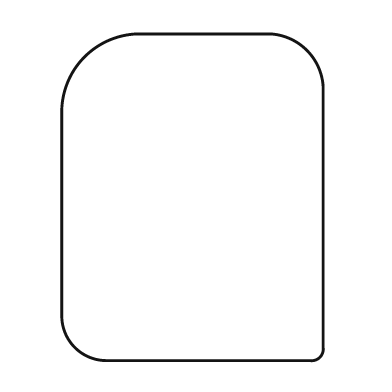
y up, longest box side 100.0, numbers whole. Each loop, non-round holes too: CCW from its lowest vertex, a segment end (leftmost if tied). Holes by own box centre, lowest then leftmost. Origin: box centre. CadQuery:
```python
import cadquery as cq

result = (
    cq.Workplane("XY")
    .moveTo(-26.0, -50.0)
    .lineTo(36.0, -50.0)
    .threePointArc((39.0, -49.0), (40.0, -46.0))
    .lineTo(40.0, 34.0)
    .threePointArc((35.0, 45.0), (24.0, 50.0))
    .lineTo(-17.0, 50.0)
    .threePointArc((-33.0, 43.0), (-40.0, 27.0))
    .lineTo(-40.0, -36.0)
    .threePointArc((-36.0, -46.0), (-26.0, -50.0))
    .close()
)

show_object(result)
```